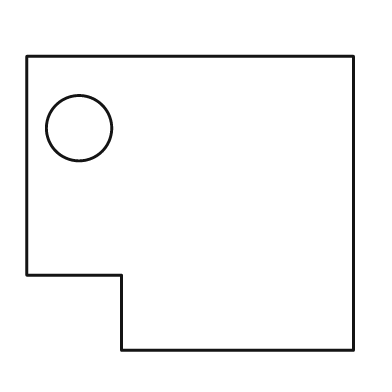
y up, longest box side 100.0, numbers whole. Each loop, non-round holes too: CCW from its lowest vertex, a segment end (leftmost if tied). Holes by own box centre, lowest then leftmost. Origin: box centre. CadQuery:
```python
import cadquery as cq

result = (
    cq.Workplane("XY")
    .moveTo(-21.0, -45.0)
    .lineTo(50.0, -45.0)
    .lineTo(50.0, 45.0)
    .lineTo(-50.0, 45.0)
    .lineTo(-50.0, -22.0)
    .lineTo(-21.0, -22.0)
    .close()
    .moveTo(-34.0, 23.0)
    .circle(10.0)
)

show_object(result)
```